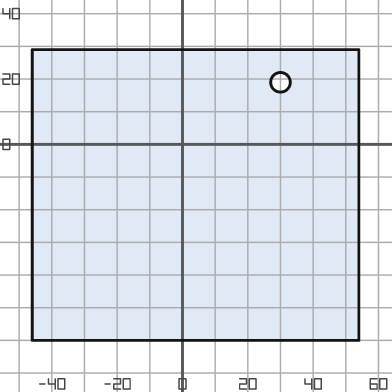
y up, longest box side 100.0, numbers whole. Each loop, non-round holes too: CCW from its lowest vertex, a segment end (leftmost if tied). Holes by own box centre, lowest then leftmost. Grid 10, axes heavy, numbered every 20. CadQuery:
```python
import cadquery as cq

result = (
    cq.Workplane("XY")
    .moveTo(-46.0, -60.0)
    .lineTo(54.0, -60.0)
    .lineTo(54.0, 29.0)
    .lineTo(-46.0, 29.0)
    .close()
    .moveTo(30.0, 19.0)
    .circle(3.0)
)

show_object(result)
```